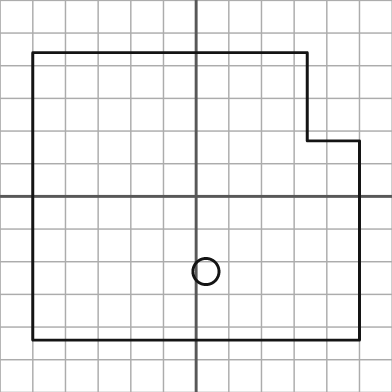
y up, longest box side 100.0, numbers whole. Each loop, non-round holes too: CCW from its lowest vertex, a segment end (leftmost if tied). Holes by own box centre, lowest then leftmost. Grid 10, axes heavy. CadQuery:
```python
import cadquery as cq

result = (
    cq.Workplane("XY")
    .moveTo(-50.0, -44.0)
    .lineTo(50.0, -44.0)
    .lineTo(50.0, 17.0)
    .lineTo(34.0, 17.0)
    .lineTo(34.0, 44.0)
    .lineTo(-50.0, 44.0)
    .close()
    .moveTo(3.0, -23.0)
    .circle(4.0)
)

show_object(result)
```